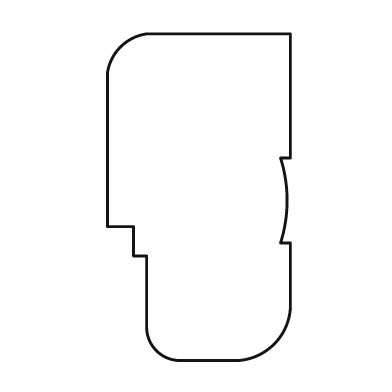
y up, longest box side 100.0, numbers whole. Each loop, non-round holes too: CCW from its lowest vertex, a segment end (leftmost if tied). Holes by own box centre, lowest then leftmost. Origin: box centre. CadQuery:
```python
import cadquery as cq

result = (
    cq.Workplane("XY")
    .moveTo(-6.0, -50.0)
    .lineTo(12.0, -50.0)
    .threePointArc((23.0, -45.0), (28.0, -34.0))
    .lineTo(28.0, -14.0)
    .lineTo(25.0, -14.0)
    .threePointArc((27.0, -1.0), (25.0, 12.0))
    .lineTo(28.0, 12.0)
    .lineTo(28.0, 50.0)
    .lineTo(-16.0, 50.0)
    .threePointArc((-24.0, 46.0), (-28.0, 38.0))
    .lineTo(-28.0, -9.0)
    .lineTo(-20.0, -9.0)
    .lineTo(-20.0, -18.0)
    .lineTo(-16.0, -18.0)
    .lineTo(-16.0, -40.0)
    .threePointArc((-13.0, -47.0), (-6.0, -50.0))
    .close()
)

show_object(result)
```